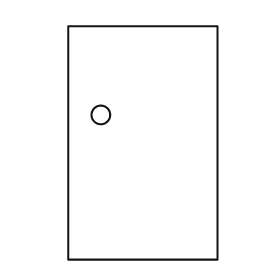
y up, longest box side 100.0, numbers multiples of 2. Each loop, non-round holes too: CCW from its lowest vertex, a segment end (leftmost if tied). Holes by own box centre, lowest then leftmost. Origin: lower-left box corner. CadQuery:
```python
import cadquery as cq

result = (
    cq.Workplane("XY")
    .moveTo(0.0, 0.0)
    .lineTo(64.0, 0.0)
    .lineTo(64.0, 100.0)
    .lineTo(0.0, 100.0)
    .close()
    .moveTo(14.0, 62.0)
    .circle(4.0)
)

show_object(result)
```